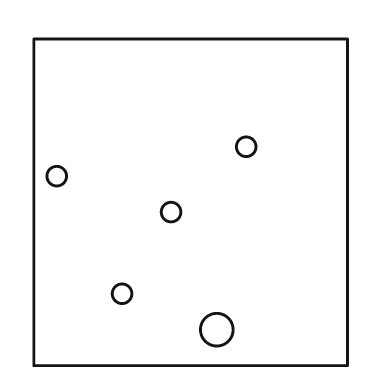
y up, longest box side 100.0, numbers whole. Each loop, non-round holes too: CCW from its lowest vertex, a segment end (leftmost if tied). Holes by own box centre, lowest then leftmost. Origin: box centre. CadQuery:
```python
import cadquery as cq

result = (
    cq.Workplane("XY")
    .moveTo(-48.0, -50.0)
    .lineTo(48.0, -50.0)
    .lineTo(48.0, 50.0)
    .lineTo(-48.0, 50.0)
    .close()
    .moveTo(8.0, -39.0)
    .circle(5.0)
    .moveTo(-21.0, -28.0)
    .circle(3.0)
    .moveTo(-6.0, -3.0)
    .circle(3.0)
    .moveTo(-41.0, 8.0)
    .circle(3.0)
    .moveTo(17.0, 17.0)
    .circle(3.0)
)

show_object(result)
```